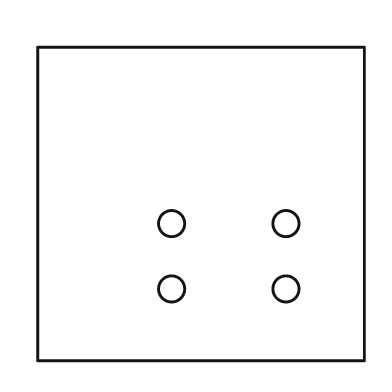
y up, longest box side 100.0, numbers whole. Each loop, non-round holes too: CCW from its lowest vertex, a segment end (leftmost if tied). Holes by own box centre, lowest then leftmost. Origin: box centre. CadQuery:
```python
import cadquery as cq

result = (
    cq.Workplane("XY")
    .moveTo(-50.0, -48.0)
    .lineTo(50.0, -48.0)
    .lineTo(50.0, 48.0)
    .lineTo(-50.0, 48.0)
    .close()
    .moveTo(-9.0, -26.0)
    .circle(4.0)
    .moveTo(26.0, -26.0)
    .circle(4.0)
    .moveTo(-9.0, -6.0)
    .circle(4.0)
    .moveTo(26.0, -6.0)
    .circle(4.0)
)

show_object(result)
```